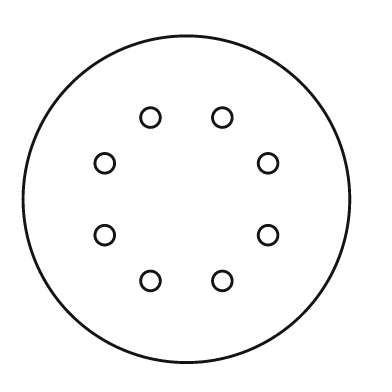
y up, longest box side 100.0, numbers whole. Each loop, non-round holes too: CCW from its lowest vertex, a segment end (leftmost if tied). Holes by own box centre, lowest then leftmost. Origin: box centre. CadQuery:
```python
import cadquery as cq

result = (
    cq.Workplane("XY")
    .moveTo(0.0, 0.0)
    .circle(50.0)
    .moveTo(-11.0, -25.0)
    .circle(3.0)
    .moveTo(11.0, -25.0)
    .circle(3.0)
    .moveTo(-25.0, -11.0)
    .circle(3.0)
    .moveTo(25.0, -11.0)
    .circle(3.0)
    .moveTo(-25.0, 11.0)
    .circle(3.0)
    .moveTo(25.0, 11.0)
    .circle(3.0)
    .moveTo(-11.0, 25.0)
    .circle(3.0)
    .moveTo(11.0, 25.0)
    .circle(3.0)
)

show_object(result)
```